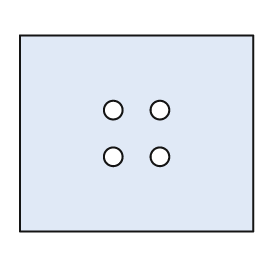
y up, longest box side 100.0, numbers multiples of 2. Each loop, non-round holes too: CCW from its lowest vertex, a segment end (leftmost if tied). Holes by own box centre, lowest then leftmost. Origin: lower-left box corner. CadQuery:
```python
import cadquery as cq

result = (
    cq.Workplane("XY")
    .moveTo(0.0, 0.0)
    .lineTo(100.0, 0.0)
    .lineTo(100.0, 84.0)
    .lineTo(0.0, 84.0)
    .close()
    .moveTo(40.0, 32.0)
    .circle(4.0)
    .moveTo(60.0, 32.0)
    .circle(4.0)
    .moveTo(40.0, 52.0)
    .circle(4.0)
    .moveTo(60.0, 52.0)
    .circle(4.0)
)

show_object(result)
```